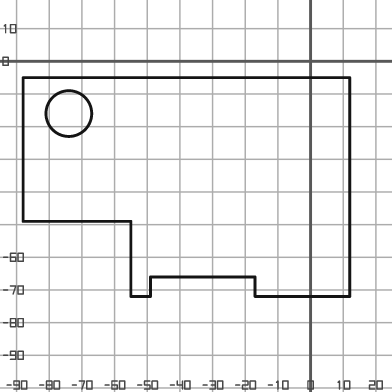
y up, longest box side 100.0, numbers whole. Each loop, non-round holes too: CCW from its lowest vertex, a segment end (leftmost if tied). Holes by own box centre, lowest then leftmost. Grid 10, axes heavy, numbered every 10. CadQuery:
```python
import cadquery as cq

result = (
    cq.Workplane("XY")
    .moveTo(-55.0, -72.0)
    .lineTo(-49.0, -72.0)
    .lineTo(-49.0, -66.0)
    .lineTo(-17.0, -66.0)
    .lineTo(-17.0, -72.0)
    .lineTo(12.0, -72.0)
    .lineTo(12.0, -5.0)
    .lineTo(-88.0, -5.0)
    .lineTo(-88.0, -49.0)
    .lineTo(-55.0, -49.0)
    .close()
    .moveTo(-74.0, -16.0)
    .circle(7.0)
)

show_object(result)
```